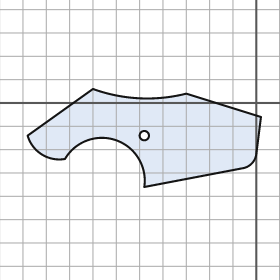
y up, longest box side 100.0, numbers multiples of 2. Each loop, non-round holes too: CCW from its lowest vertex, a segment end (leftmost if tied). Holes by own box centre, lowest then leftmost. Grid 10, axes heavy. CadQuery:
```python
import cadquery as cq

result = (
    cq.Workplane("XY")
    .moveTo(-48.0, -36.0)
    .lineTo(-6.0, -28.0)
    .threePointArc((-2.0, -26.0), (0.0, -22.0))
    .lineTo(2.0, -6.0)
    .lineTo(-30.0, 4.0)
    .threePointArc((-50.0, 2.0), (-70.0, 6.0))
    .lineTo(-98.0, -14.0)
    .threePointArc((-92.0, -22.0), (-82.0, -24.0))
    .threePointArc((-60.0, -16.0), (-48.0, -36.0))
    .close()
    .moveTo(-48.0, -14.0)
    .circle(2.0)
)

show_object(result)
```